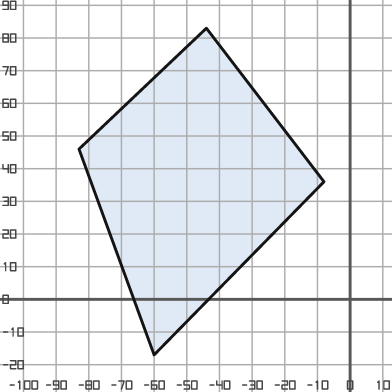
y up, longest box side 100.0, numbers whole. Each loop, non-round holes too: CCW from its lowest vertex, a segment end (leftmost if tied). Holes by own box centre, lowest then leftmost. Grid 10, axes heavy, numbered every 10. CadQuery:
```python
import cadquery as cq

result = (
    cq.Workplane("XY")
    .moveTo(-60.0, -17.0)
    .lineTo(-8.0, 36.0)
    .lineTo(-44.0, 83.0)
    .lineTo(-83.0, 46.0)
    .close()
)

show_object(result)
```